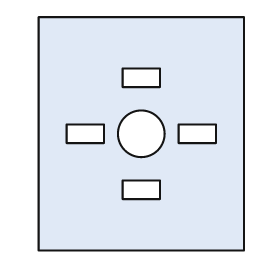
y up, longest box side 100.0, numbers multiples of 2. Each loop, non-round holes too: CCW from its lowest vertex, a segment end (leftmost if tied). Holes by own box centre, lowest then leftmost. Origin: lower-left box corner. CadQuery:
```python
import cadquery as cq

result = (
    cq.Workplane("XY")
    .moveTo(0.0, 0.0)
    .lineTo(88.0, 0.0)
    .lineTo(88.0, 100.0)
    .lineTo(0.0, 100.0)
    .close()
    .moveTo(36.0, 22.0)
    .lineTo(52.0, 22.0)
    .lineTo(52.0, 30.0)
    .lineTo(36.0, 30.0)
    .close()
    .moveTo(12.0, 46.0)
    .lineTo(28.0, 46.0)
    .lineTo(28.0, 54.0)
    .lineTo(12.0, 54.0)
    .close()
    .moveTo(44.0, 50.0)
    .circle(10.0)
    .moveTo(60.0, 46.0)
    .lineTo(76.0, 46.0)
    .lineTo(76.0, 54.0)
    .lineTo(60.0, 54.0)
    .close()
    .moveTo(36.0, 70.0)
    .lineTo(52.0, 70.0)
    .lineTo(52.0, 78.0)
    .lineTo(36.0, 78.0)
    .close()
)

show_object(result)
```